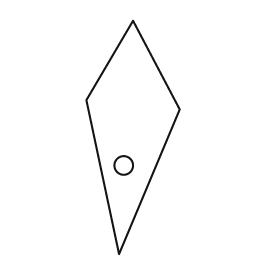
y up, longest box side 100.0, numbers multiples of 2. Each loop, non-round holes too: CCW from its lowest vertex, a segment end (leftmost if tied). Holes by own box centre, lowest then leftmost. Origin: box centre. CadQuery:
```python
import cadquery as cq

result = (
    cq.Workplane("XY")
    .moveTo(-6.0, -50.0)
    .lineTo(20.0, 12.0)
    .lineTo(0.0, 50.0)
    .lineTo(-20.0, 16.0)
    .close()
    .moveTo(-4.0, -12.0)
    .circle(4.0)
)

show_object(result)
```